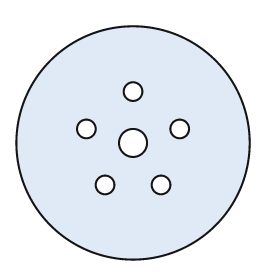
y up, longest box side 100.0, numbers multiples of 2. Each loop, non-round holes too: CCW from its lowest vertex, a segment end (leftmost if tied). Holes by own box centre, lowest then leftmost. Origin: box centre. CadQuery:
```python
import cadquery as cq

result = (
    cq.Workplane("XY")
    .moveTo(0.0, 0.0)
    .circle(50.0)
    .moveTo(-12.0, -18.0)
    .circle(4.0)
    .moveTo(12.0, -18.0)
    .circle(4.0)
    .moveTo(0.0, 0.0)
    .circle(6.0)
    .moveTo(-20.0, 6.0)
    .circle(4.0)
    .moveTo(20.0, 6.0)
    .circle(4.0)
    .moveTo(0.0, 22.0)
    .circle(4.0)
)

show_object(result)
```